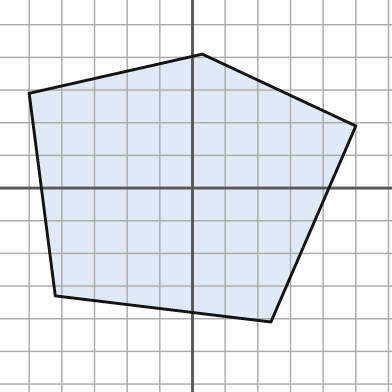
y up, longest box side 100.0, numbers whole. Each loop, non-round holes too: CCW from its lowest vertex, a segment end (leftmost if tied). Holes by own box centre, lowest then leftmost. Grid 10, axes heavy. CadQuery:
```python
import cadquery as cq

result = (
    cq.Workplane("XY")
    .moveTo(24.0, -41.0)
    .lineTo(50.0, 19.0)
    .lineTo(3.0, 41.0)
    .lineTo(-50.0, 29.0)
    .lineTo(-42.0, -33.0)
    .close()
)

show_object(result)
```